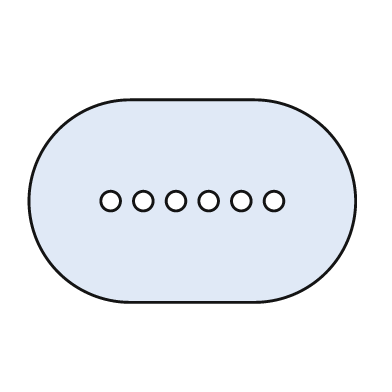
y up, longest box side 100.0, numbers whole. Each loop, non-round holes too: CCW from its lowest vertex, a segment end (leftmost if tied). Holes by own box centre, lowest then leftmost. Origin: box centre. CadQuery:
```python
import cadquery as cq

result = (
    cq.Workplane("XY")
    .moveTo(-19.0, -31.0)
    .lineTo(19.0, -31.0)
    .threePointArc((50.0, 0.0), (19.0, 31.0))
    .lineTo(-19.0, 31.0)
    .threePointArc((-50.0, 0.0), (-19.0, -31.0))
    .close()
    .moveTo(-25.0, 0.0)
    .circle(3.0)
    .moveTo(-15.0, 0.0)
    .circle(3.0)
    .moveTo(-5.0, 0.0)
    .circle(3.0)
    .moveTo(5.0, 0.0)
    .circle(3.0)
    .moveTo(15.0, 0.0)
    .circle(3.0)
    .moveTo(25.0, 0.0)
    .circle(3.0)
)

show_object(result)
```